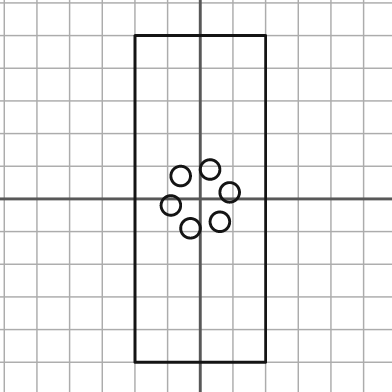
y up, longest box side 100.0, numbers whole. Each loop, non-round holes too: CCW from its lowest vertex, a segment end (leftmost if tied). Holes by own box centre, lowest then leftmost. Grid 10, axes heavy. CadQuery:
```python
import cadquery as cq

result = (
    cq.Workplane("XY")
    .moveTo(-20.0, -50.0)
    .lineTo(20.0, -50.0)
    .lineTo(20.0, 50.0)
    .lineTo(-20.0, 50.0)
    .close()
    .moveTo(-3.0, -9.0)
    .circle(3.0)
    .moveTo(6.0, -7.0)
    .circle(3.0)
    .moveTo(-9.0, -2.0)
    .circle(3.0)
    .moveTo(9.0, 2.0)
    .circle(3.0)
    .moveTo(-6.0, 7.0)
    .circle(3.0)
    .moveTo(3.0, 9.0)
    .circle(3.0)
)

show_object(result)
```